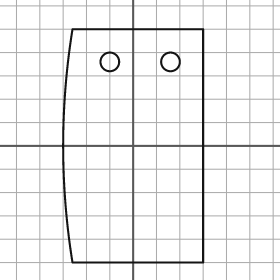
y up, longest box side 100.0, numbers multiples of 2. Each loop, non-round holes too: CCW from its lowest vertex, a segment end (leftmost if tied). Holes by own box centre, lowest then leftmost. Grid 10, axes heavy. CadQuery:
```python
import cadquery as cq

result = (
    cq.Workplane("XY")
    .moveTo(-26.0, -50.0)
    .lineTo(30.0, -50.0)
    .lineTo(30.0, 50.0)
    .lineTo(-26.0, 50.0)
    .threePointArc((-30.0, 0.0), (-26.0, -50.0))
    .close()
    .moveTo(-10.0, 36.0)
    .circle(4.0)
    .moveTo(16.0, 36.0)
    .circle(4.0)
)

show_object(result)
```